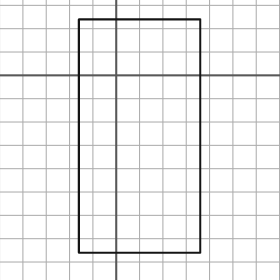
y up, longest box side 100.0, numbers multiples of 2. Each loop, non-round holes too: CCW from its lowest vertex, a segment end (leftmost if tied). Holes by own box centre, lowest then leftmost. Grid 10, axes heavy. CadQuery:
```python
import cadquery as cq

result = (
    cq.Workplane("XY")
    .moveTo(-16.0, -76.0)
    .lineTo(36.0, -76.0)
    .lineTo(36.0, 24.0)
    .lineTo(-16.0, 24.0)
    .close()
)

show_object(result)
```